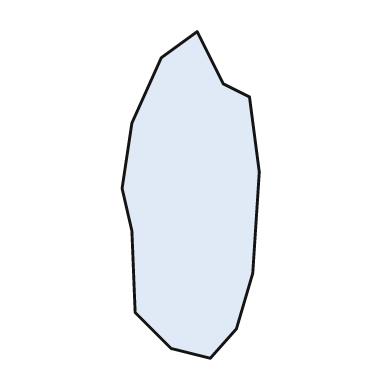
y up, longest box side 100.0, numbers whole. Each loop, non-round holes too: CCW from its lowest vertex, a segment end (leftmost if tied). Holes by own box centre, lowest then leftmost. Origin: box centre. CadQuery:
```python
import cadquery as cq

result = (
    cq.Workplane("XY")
    .moveTo(6.0, -50.0)
    .lineTo(14.0, -41.0)
    .lineTo(19.0, -24.0)
    .lineTo(21.0, 7.0)
    .lineTo(18.0, 30.0)
    .lineTo(10.0, 34.0)
    .lineTo(2.0, 50.0)
    .lineTo(-9.0, 42.0)
    .lineTo(-18.0, 22.0)
    .lineTo(-21.0, 2.0)
    .lineTo(-18.0, -11.0)
    .lineTo(-17.0, -36.0)
    .lineTo(-6.0, -47.0)
    .close()
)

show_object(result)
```